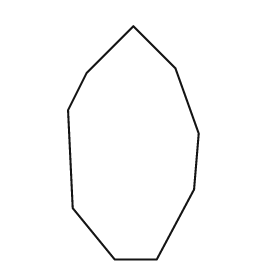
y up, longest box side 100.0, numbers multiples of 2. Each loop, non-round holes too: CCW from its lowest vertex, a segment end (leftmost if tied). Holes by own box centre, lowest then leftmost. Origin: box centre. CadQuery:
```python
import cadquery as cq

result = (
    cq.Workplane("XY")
    .moveTo(-8.0, -50.0)
    .lineTo(10.0, -50.0)
    .lineTo(26.0, -20.0)
    .lineTo(28.0, 4.0)
    .lineTo(18.0, 32.0)
    .lineTo(0.0, 50.0)
    .lineTo(-20.0, 30.0)
    .lineTo(-28.0, 14.0)
    .lineTo(-26.0, -28.0)
    .close()
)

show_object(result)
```